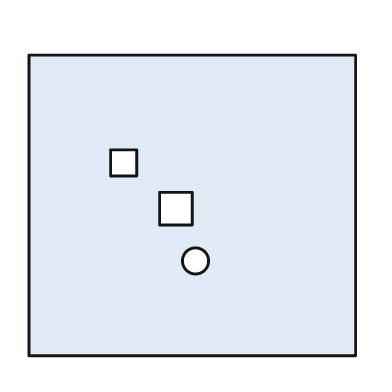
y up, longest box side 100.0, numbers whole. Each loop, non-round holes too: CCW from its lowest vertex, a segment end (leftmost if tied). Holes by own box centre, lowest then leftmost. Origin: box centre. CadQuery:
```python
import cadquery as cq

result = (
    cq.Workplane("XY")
    .moveTo(-50.0, -46.0)
    .lineTo(50.0, -46.0)
    .lineTo(50.0, 46.0)
    .lineTo(-50.0, 46.0)
    .close()
    .moveTo(1.0, -17.0)
    .circle(4.0)
    .moveTo(-10.0, -6.0)
    .lineTo(0.0, -6.0)
    .lineTo(0.0, 4.0)
    .lineTo(-10.0, 4.0)
    .close()
    .moveTo(-25.0, 9.0)
    .lineTo(-17.0, 9.0)
    .lineTo(-17.0, 17.0)
    .lineTo(-25.0, 17.0)
    .close()
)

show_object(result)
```